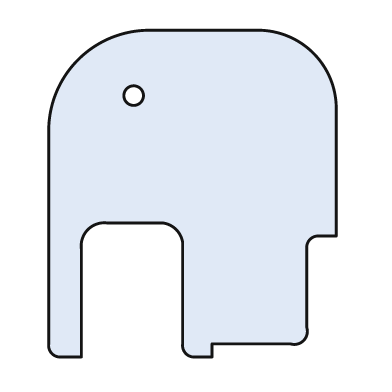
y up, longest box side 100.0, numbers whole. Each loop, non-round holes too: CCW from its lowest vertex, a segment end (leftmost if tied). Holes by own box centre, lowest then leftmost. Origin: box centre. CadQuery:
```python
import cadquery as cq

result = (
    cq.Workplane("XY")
    .moveTo(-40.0, -50.0)
    .lineTo(-34.0, -50.0)
    .lineTo(-34.0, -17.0)
    .threePointArc((-32.0, -11.0), (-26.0, -9.0))
    .lineTo(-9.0, -9.0)
    .threePointArc((-5.0, -11.0), (-3.0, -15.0))
    .lineTo(-3.0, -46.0)
    .threePointArc((-2.0, -49.0), (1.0, -50.0))
    .lineTo(6.0, -50.0)
    .lineTo(6.0, -46.0)
    .lineTo(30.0, -46.0)
    .threePointArc((34.0, -45.0), (35.0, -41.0))
    .lineTo(35.0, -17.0)
    .threePointArc((36.0, -14.0), (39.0, -13.0))
    .lineTo(44.0, -13.0)
    .lineTo(44.0, 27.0)
    .threePointArc((37.0, 43.0), (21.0, 50.0))
    .lineTo(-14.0, 50.0)
    .threePointArc((-35.0, 41.0), (-44.0, 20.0))
    .lineTo(-44.0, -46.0)
    .threePointArc((-43.0, -49.0), (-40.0, -50.0))
    .close()
    .moveTo(-18.0, 30.0)
    .circle(3.0)
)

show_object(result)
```